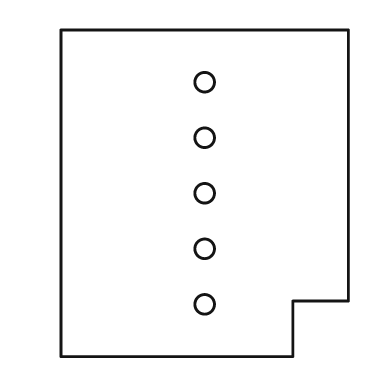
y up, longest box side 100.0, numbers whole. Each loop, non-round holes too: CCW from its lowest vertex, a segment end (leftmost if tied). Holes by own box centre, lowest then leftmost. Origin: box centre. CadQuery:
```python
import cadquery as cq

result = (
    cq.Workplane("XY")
    .moveTo(-44.0, -50.0)
    .lineTo(27.0, -50.0)
    .lineTo(27.0, -33.0)
    .lineTo(44.0, -33.0)
    .lineTo(44.0, 50.0)
    .lineTo(-44.0, 50.0)
    .close()
    .moveTo(0.0, -34.0)
    .circle(3.0)
    .moveTo(0.0, -17.0)
    .circle(3.0)
    .moveTo(0.0, 0.0)
    .circle(3.0)
    .moveTo(0.0, 17.0)
    .circle(3.0)
    .moveTo(0.0, 34.0)
    .circle(3.0)
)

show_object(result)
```